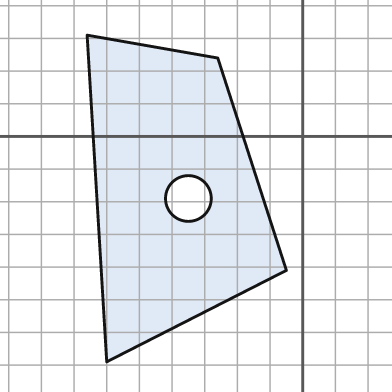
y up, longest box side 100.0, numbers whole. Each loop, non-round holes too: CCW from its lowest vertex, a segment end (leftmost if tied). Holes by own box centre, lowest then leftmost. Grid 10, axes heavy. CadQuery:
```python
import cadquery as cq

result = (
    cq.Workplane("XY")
    .moveTo(-60.0, -69.0)
    .lineTo(-5.0, -41.0)
    .lineTo(-26.0, 24.0)
    .lineTo(-66.0, 31.0)
    .close()
    .moveTo(-35.0, -19.0)
    .circle(7.0)
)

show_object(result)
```